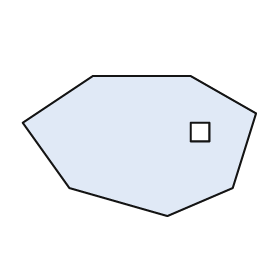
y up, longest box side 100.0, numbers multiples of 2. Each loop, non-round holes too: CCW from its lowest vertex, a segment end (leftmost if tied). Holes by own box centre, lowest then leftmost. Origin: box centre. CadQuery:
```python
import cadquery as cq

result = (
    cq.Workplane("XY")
    .moveTo(12.0, -30.0)
    .lineTo(40.0, -18.0)
    .lineTo(50.0, 14.0)
    .lineTo(22.0, 30.0)
    .lineTo(-20.0, 30.0)
    .lineTo(-50.0, 10.0)
    .lineTo(-30.0, -18.0)
    .close()
    .moveTo(22.0, 2.0)
    .lineTo(30.0, 2.0)
    .lineTo(30.0, 10.0)
    .lineTo(22.0, 10.0)
    .close()
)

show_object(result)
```